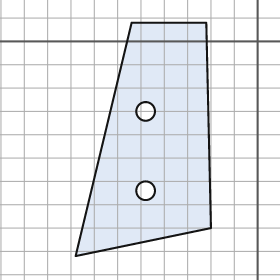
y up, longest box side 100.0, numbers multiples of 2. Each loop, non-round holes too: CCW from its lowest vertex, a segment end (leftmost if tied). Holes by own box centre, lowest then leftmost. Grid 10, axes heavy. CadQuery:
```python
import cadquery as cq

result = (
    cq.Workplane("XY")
    .moveTo(-78.0, -92.0)
    .lineTo(-20.0, -80.0)
    .lineTo(-22.0, 8.0)
    .lineTo(-54.0, 8.0)
    .close()
    .moveTo(-48.0, -64.0)
    .circle(4.0)
    .moveTo(-48.0, -30.0)
    .circle(4.0)
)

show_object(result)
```